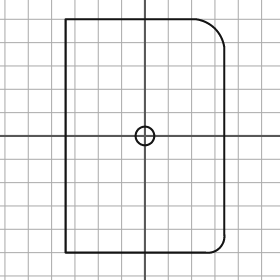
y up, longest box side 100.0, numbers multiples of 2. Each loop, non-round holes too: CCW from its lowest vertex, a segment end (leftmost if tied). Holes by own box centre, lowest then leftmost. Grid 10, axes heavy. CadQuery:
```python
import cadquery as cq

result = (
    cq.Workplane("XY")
    .moveTo(-34.0, -50.0)
    .lineTo(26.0, -50.0)
    .threePointArc((32.0, -48.0), (34.0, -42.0))
    .lineTo(34.0, 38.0)
    .threePointArc((30.0, 46.0), (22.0, 50.0))
    .lineTo(-34.0, 50.0)
    .close()
    .moveTo(0.0, 0.0)
    .circle(4.0)
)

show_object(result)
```